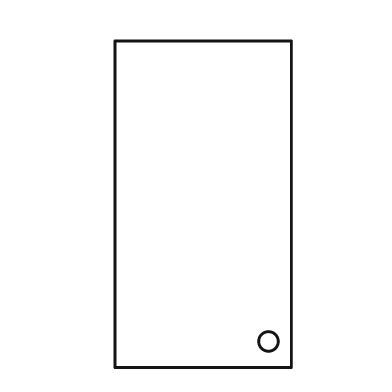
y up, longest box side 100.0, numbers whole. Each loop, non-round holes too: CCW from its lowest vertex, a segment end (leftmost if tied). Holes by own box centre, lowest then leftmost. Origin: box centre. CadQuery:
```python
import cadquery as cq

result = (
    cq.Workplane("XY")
    .moveTo(-27.0, -50.0)
    .lineTo(27.0, -50.0)
    .lineTo(27.0, 50.0)
    .lineTo(-27.0, 50.0)
    .close()
    .moveTo(20.0, -42.0)
    .circle(3.0)
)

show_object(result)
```